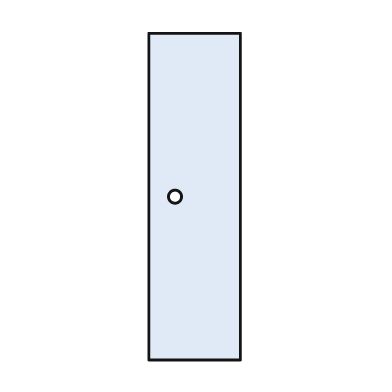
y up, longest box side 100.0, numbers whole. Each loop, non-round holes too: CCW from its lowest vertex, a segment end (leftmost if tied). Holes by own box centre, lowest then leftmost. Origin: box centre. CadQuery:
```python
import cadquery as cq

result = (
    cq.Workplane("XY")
    .moveTo(-14.0, -50.0)
    .lineTo(14.0, -50.0)
    .lineTo(14.0, 50.0)
    .lineTo(-14.0, 50.0)
    .close()
    .moveTo(-6.0, 0.0)
    .circle(2.0)
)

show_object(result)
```